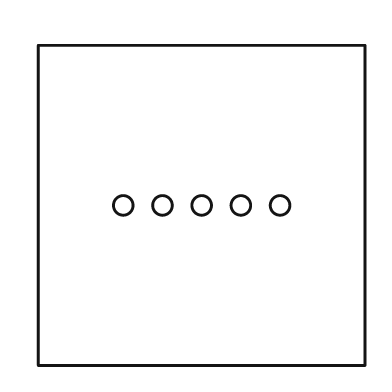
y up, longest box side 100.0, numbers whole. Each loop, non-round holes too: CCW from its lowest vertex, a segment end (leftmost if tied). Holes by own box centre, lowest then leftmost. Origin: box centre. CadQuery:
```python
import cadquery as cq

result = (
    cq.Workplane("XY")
    .moveTo(-50.0, -49.0)
    .lineTo(50.0, -49.0)
    .lineTo(50.0, 49.0)
    .lineTo(-50.0, 49.0)
    .close()
    .moveTo(-24.0, 0.0)
    .circle(3.0)
    .moveTo(-12.0, 0.0)
    .circle(3.0)
    .moveTo(0.0, 0.0)
    .circle(3.0)
    .moveTo(12.0, 0.0)
    .circle(3.0)
    .moveTo(24.0, 0.0)
    .circle(3.0)
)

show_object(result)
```